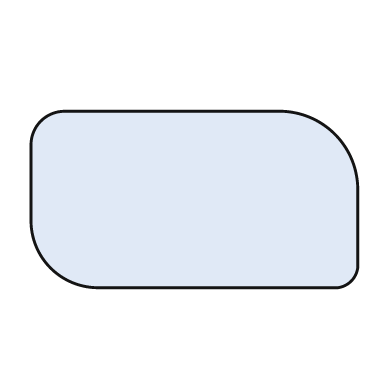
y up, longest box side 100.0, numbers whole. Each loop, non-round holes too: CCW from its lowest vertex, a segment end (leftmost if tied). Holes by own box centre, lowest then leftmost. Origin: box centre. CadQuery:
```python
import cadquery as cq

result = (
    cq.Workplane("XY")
    .moveTo(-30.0, -27.0)
    .lineTo(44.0, -27.0)
    .threePointArc((48.0, -25.0), (50.0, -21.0))
    .lineTo(50.0, 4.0)
    .threePointArc((43.0, 20.0), (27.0, 27.0))
    .lineTo(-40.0, 27.0)
    .threePointArc((-47.0, 24.0), (-50.0, 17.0))
    .lineTo(-50.0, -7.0)
    .threePointArc((-44.0, -21.0), (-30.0, -27.0))
    .close()
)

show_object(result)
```